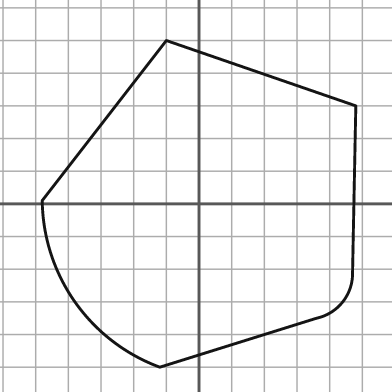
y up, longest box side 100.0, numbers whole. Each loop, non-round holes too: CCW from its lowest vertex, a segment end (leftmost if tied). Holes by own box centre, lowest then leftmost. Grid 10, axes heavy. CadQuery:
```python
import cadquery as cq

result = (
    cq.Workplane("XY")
    .moveTo(-12.0, -50.0)
    .lineTo(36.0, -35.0)
    .threePointArc((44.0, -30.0), (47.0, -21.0))
    .lineTo(48.0, 30.0)
    .lineTo(-10.0, 50.0)
    .lineTo(-48.0, 1.0)
    .threePointArc((-38.0, -30.0), (-12.0, -50.0))
    .close()
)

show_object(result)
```